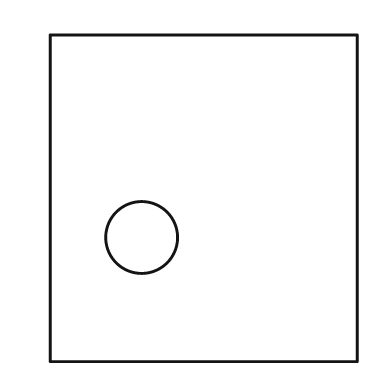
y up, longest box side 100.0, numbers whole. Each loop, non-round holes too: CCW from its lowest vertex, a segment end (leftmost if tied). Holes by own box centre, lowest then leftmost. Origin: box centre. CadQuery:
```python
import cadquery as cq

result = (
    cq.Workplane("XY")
    .moveTo(-47.0, -50.0)
    .lineTo(47.0, -50.0)
    .lineTo(47.0, 50.0)
    .lineTo(-47.0, 50.0)
    .close()
    .moveTo(-19.0, -12.0)
    .circle(11.0)
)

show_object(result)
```